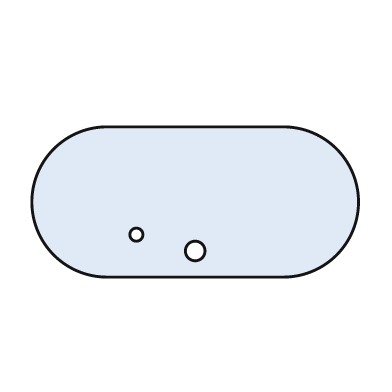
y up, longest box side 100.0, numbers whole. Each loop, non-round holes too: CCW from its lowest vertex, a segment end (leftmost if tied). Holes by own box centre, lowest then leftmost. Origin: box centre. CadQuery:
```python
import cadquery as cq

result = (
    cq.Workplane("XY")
    .moveTo(-27.0, -23.0)
    .lineTo(27.0, -23.0)
    .threePointArc((50.0, 0.0), (27.0, 23.0))
    .lineTo(-27.0, 23.0)
    .threePointArc((-50.0, 0.0), (-27.0, -23.0))
    .close()
    .moveTo(0.0, -15.0)
    .circle(3.0)
    .moveTo(-18.0, -10.0)
    .circle(2.0)
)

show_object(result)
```